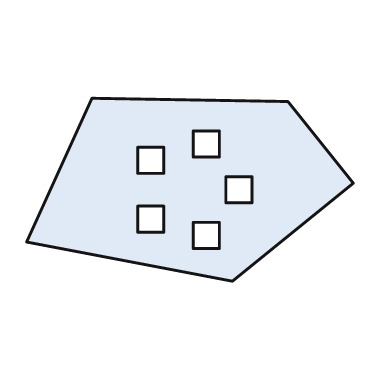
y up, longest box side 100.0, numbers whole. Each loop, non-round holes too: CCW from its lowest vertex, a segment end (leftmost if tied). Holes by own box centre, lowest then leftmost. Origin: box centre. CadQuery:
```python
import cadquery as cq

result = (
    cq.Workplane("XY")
    .moveTo(13.0, -28.0)
    .lineTo(50.0, 2.0)
    .lineTo(30.0, 27.0)
    .lineTo(-30.0, 28.0)
    .lineTo(-50.0, -16.0)
    .close()
    .moveTo(1.0, -18.0)
    .lineTo(9.0, -18.0)
    .lineTo(9.0, -10.0)
    .lineTo(1.0, -10.0)
    .close()
    .moveTo(-16.0, -13.0)
    .lineTo(-8.0, -13.0)
    .lineTo(-8.0, -5.0)
    .lineTo(-16.0, -5.0)
    .close()
    .moveTo(11.0, -4.0)
    .lineTo(19.0, -4.0)
    .lineTo(19.0, 4.0)
    .lineTo(11.0, 4.0)
    .close()
    .moveTo(-16.0, 5.0)
    .lineTo(-8.0, 5.0)
    .lineTo(-8.0, 13.0)
    .lineTo(-16.0, 13.0)
    .close()
    .moveTo(1.0, 10.0)
    .lineTo(9.0, 10.0)
    .lineTo(9.0, 18.0)
    .lineTo(1.0, 18.0)
    .close()
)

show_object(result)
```